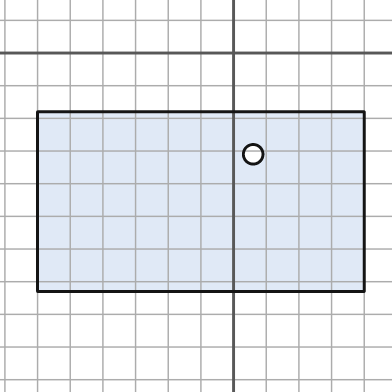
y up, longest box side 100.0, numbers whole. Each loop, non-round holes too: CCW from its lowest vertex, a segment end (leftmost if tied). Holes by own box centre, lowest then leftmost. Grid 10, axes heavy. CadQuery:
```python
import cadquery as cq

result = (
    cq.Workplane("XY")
    .moveTo(-60.0, -73.0)
    .lineTo(40.0, -73.0)
    .lineTo(40.0, -18.0)
    .lineTo(-60.0, -18.0)
    .close()
    .moveTo(6.0, -31.0)
    .circle(3.0)
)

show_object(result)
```